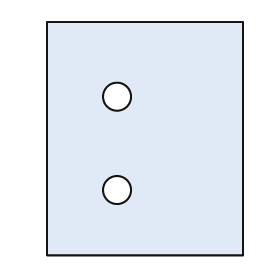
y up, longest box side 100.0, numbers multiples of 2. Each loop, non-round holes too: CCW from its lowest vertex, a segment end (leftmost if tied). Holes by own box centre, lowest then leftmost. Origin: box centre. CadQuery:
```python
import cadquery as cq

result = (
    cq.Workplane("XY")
    .moveTo(-42.0, -50.0)
    .lineTo(42.0, -50.0)
    .lineTo(42.0, 50.0)
    .lineTo(-42.0, 50.0)
    .close()
    .moveTo(-12.0, -22.0)
    .circle(6.0)
    .moveTo(-12.0, 18.0)
    .circle(6.0)
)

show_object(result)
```